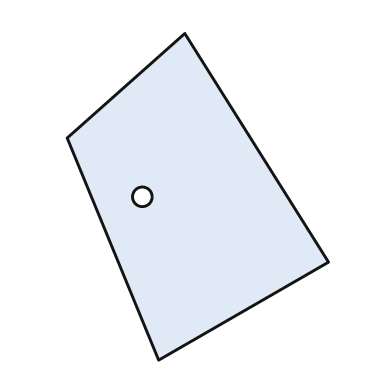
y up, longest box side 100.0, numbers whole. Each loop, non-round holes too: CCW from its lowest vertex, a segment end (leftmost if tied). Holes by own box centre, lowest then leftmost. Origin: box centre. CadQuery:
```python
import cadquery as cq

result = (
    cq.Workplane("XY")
    .moveTo(-12.0, -50.0)
    .lineTo(40.0, -20.0)
    .lineTo(-4.0, 50.0)
    .lineTo(-40.0, 18.0)
    .close()
    .moveTo(-17.0, 0.0)
    .circle(3.0)
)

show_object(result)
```